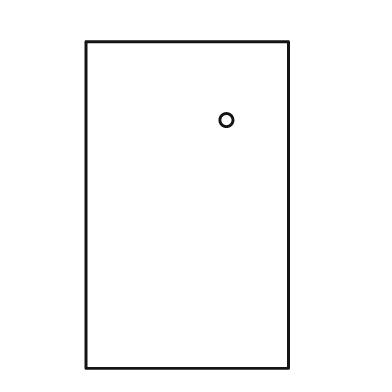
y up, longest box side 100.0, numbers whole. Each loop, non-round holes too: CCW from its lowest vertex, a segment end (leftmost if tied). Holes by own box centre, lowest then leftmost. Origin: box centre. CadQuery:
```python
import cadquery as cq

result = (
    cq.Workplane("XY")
    .moveTo(-31.0, -50.0)
    .lineTo(31.0, -50.0)
    .lineTo(31.0, 50.0)
    .lineTo(-31.0, 50.0)
    .close()
    .moveTo(12.0, 26.0)
    .circle(2.0)
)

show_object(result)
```